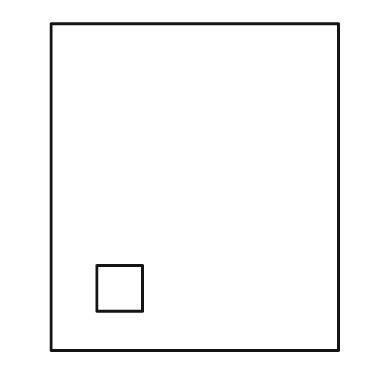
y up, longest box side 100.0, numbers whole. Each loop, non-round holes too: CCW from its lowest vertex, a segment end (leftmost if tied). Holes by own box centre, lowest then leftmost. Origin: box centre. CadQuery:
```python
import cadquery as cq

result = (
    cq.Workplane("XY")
    .moveTo(-44.0, -50.0)
    .lineTo(44.0, -50.0)
    .lineTo(44.0, 50.0)
    .lineTo(-44.0, 50.0)
    .close()
    .moveTo(-30.0, -38.0)
    .lineTo(-16.0, -38.0)
    .lineTo(-16.0, -24.0)
    .lineTo(-30.0, -24.0)
    .close()
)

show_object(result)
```